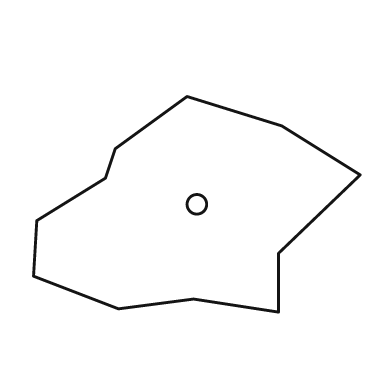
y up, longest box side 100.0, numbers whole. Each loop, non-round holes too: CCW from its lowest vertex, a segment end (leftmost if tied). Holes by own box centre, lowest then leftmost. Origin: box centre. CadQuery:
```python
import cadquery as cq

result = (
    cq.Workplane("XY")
    .moveTo(25.0, -33.0)
    .lineTo(25.0, -15.0)
    .lineTo(50.0, 9.0)
    .lineTo(26.0, 24.0)
    .lineTo(-3.0, 33.0)
    .lineTo(-25.0, 17.0)
    .lineTo(-28.0, 8.0)
    .lineTo(-49.0, -5.0)
    .lineTo(-50.0, -22.0)
    .lineTo(-24.0, -32.0)
    .lineTo(-1.0, -29.0)
    .close()
    .moveTo(0.0, 0.0)
    .circle(3.0)
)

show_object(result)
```